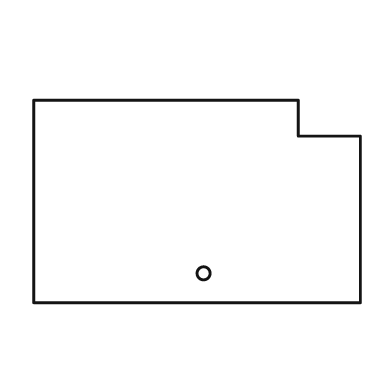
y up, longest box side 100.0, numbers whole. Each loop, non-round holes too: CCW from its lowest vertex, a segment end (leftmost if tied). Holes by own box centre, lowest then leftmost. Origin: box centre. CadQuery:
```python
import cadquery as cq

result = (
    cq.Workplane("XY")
    .moveTo(-50.0, -31.0)
    .lineTo(50.0, -31.0)
    .lineTo(50.0, 20.0)
    .lineTo(31.0, 20.0)
    .lineTo(31.0, 31.0)
    .lineTo(-50.0, 31.0)
    .close()
    .moveTo(2.0, -22.0)
    .circle(2.0)
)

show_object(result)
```